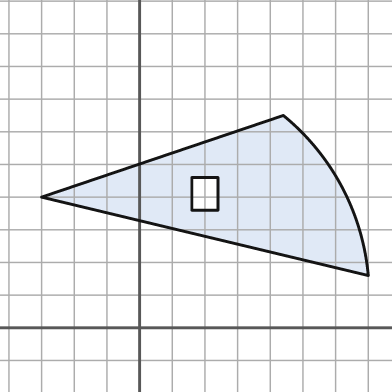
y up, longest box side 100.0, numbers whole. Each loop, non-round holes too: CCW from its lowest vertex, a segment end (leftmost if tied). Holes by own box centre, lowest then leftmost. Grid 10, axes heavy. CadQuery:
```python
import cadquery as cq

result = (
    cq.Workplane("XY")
    .moveTo(70.0, 16.0)
    .threePointArc((62.0, 43.0), (44.0, 65.0))
    .lineTo(-30.0, 40.0)
    .close()
    .moveTo(16.0, 36.0)
    .lineTo(24.0, 36.0)
    .lineTo(24.0, 46.0)
    .lineTo(16.0, 46.0)
    .close()
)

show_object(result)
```